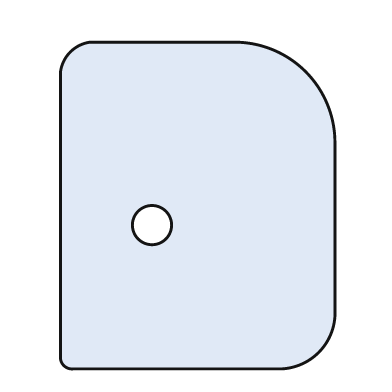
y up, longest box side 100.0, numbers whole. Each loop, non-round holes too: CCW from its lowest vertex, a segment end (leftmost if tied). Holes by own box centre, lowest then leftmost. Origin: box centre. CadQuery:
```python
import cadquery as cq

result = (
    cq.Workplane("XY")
    .moveTo(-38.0, -50.0)
    .lineTo(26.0, -50.0)
    .threePointArc((37.0, -45.0), (42.0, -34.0))
    .lineTo(42.0, 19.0)
    .threePointArc((33.0, 41.0), (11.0, 50.0))
    .lineTo(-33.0, 50.0)
    .threePointArc((-39.0, 47.0), (-42.0, 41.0))
    .lineTo(-42.0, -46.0)
    .threePointArc((-41.0, -49.0), (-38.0, -50.0))
    .close()
    .moveTo(-14.0, -6.0)
    .circle(6.0)
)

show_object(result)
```